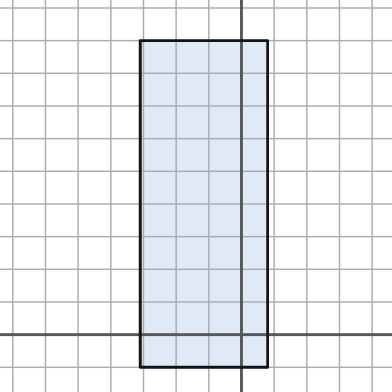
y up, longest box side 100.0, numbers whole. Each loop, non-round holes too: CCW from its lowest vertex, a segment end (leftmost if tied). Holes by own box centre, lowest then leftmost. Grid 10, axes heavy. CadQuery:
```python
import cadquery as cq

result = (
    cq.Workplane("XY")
    .moveTo(-31.0, -10.0)
    .lineTo(8.0, -10.0)
    .lineTo(8.0, 90.0)
    .lineTo(-31.0, 90.0)
    .close()
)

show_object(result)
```